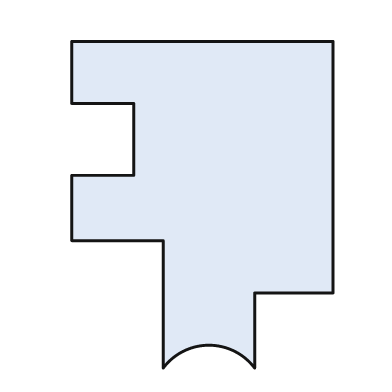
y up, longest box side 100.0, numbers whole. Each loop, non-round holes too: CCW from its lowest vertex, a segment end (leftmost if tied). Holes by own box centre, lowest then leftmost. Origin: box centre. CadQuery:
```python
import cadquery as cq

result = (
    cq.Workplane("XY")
    .moveTo(-12.0, -50.0)
    .threePointArc((2.0, -43.0), (16.0, -50.0))
    .lineTo(16.0, -27.0)
    .lineTo(40.0, -27.0)
    .lineTo(40.0, 50.0)
    .lineTo(-40.0, 50.0)
    .lineTo(-40.0, 31.0)
    .lineTo(-21.0, 31.0)
    .lineTo(-21.0, 9.0)
    .lineTo(-40.0, 9.0)
    .lineTo(-40.0, -11.0)
    .lineTo(-12.0, -11.0)
    .close()
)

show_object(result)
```